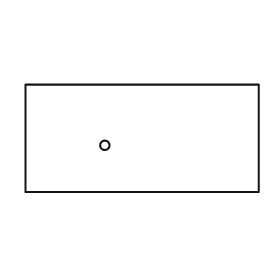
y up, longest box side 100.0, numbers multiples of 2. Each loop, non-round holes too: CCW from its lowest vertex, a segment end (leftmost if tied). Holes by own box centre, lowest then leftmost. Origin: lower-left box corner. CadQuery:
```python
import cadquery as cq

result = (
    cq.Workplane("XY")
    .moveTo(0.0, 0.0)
    .lineTo(100.0, 0.0)
    .lineTo(100.0, 46.0)
    .lineTo(0.0, 46.0)
    .close()
    .moveTo(34.0, 20.0)
    .circle(2.0)
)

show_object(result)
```